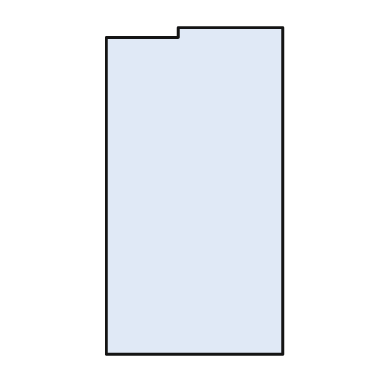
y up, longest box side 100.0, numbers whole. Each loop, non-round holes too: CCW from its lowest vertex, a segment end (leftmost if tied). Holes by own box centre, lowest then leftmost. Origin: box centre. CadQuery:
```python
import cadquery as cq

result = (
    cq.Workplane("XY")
    .moveTo(-27.0, -50.0)
    .lineTo(27.0, -50.0)
    .lineTo(27.0, 50.0)
    .lineTo(-5.0, 50.0)
    .lineTo(-5.0, 47.0)
    .lineTo(-27.0, 47.0)
    .close()
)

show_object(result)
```